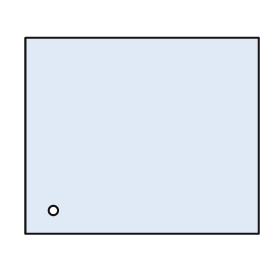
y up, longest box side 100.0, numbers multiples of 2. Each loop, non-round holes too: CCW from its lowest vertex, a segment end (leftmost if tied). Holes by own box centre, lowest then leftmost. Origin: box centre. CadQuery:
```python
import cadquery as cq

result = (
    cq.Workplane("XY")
    .moveTo(-50.0, -42.0)
    .lineTo(50.0, -42.0)
    .lineTo(50.0, 42.0)
    .lineTo(-50.0, 42.0)
    .close()
    .moveTo(-38.0, -32.0)
    .circle(2.0)
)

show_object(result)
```